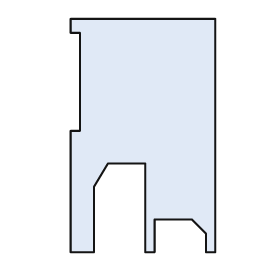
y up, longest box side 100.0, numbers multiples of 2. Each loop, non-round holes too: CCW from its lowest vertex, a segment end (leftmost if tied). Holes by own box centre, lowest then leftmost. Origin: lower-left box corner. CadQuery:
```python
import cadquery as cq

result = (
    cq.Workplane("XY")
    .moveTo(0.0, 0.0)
    .lineTo(10.0, 0.0)
    .lineTo(10.0, 28.0)
    .lineTo(16.0, 38.0)
    .lineTo(32.0, 38.0)
    .lineTo(32.0, 0.0)
    .lineTo(36.0, 0.0)
    .lineTo(36.0, 14.0)
    .lineTo(52.0, 14.0)
    .lineTo(58.0, 8.0)
    .lineTo(58.0, 0.0)
    .lineTo(62.0, 0.0)
    .lineTo(62.0, 100.0)
    .lineTo(0.0, 100.0)
    .lineTo(0.0, 94.0)
    .lineTo(4.0, 94.0)
    .lineTo(4.0, 52.0)
    .lineTo(0.0, 52.0)
    .close()
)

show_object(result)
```